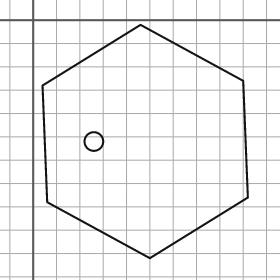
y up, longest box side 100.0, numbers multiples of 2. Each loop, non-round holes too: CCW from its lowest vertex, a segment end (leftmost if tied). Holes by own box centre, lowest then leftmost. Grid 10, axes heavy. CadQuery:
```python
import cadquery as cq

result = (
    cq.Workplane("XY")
    .moveTo(50.0, -102.0)
    .lineTo(92.0, -76.0)
    .lineTo(90.0, -26.0)
    .lineTo(46.0, -2.0)
    .lineTo(4.0, -28.0)
    .lineTo(6.0, -78.0)
    .close()
    .moveTo(26.0, -52.0)
    .circle(4.0)
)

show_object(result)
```